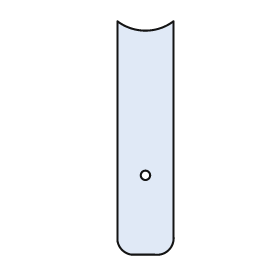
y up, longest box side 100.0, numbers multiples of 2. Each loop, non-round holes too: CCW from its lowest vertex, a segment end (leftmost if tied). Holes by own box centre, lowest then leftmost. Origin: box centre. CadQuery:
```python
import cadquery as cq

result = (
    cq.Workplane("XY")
    .moveTo(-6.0, -50.0)
    .lineTo(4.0, -50.0)
    .threePointArc((10.0, -48.0), (12.0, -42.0))
    .lineTo(12.0, 50.0)
    .threePointArc((0.0, 46.0), (-12.0, 50.0))
    .lineTo(-12.0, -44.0)
    .threePointArc((-10.0, -48.0), (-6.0, -50.0))
    .close()
    .moveTo(0.0, -16.0)
    .circle(2.0)
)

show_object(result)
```